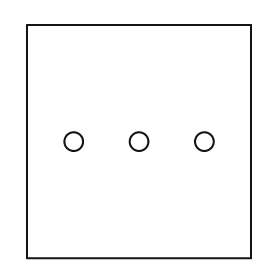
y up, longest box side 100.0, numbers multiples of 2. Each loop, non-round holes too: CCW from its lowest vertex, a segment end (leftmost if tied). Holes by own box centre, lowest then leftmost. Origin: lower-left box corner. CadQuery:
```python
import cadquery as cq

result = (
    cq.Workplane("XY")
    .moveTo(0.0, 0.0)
    .lineTo(96.0, 0.0)
    .lineTo(96.0, 100.0)
    .lineTo(0.0, 100.0)
    .close()
    .moveTo(20.0, 50.0)
    .circle(4.0)
    .moveTo(48.0, 50.0)
    .circle(4.0)
    .moveTo(76.0, 50.0)
    .circle(4.0)
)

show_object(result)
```